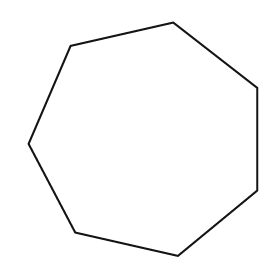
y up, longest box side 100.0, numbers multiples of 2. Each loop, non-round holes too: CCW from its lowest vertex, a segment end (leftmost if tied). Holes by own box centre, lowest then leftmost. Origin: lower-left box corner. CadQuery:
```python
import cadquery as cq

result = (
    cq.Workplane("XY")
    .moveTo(64.0, 0.0)
    .lineTo(98.0, 28.0)
    .lineTo(98.0, 72.0)
    .lineTo(62.0, 100.0)
    .lineTo(18.0, 90.0)
    .lineTo(0.0, 48.0)
    .lineTo(20.0, 10.0)
    .close()
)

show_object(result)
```